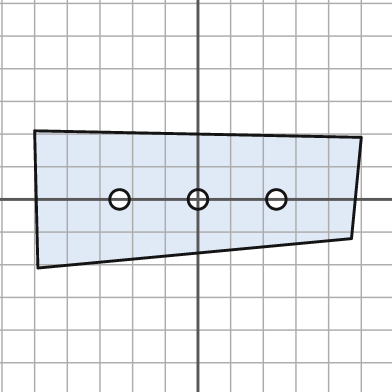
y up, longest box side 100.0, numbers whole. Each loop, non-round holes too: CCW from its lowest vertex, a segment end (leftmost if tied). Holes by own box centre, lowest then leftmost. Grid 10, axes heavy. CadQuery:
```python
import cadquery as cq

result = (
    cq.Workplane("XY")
    .moveTo(-49.0, -21.0)
    .lineTo(47.0, -12.0)
    .lineTo(50.0, 19.0)
    .lineTo(-50.0, 21.0)
    .close()
    .moveTo(-24.0, 0.0)
    .circle(3.0)
    .moveTo(0.0, 0.0)
    .circle(3.0)
    .moveTo(24.0, 0.0)
    .circle(3.0)
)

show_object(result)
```